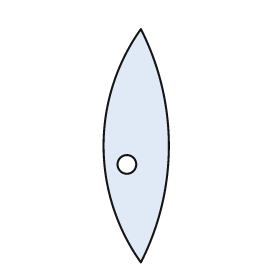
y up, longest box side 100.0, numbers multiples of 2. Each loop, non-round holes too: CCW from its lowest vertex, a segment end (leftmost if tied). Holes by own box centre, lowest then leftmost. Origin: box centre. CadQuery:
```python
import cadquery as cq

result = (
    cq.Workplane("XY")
    .moveTo(2.0, -50.0)
    .threePointArc((14.0, 0.0), (2.0, 50.0))
    .threePointArc((-14.0, 0.0), (2.0, -50.0))
    .close()
    .moveTo(-4.0, -8.0)
    .circle(4.0)
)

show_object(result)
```